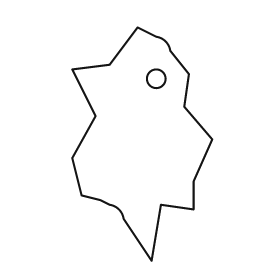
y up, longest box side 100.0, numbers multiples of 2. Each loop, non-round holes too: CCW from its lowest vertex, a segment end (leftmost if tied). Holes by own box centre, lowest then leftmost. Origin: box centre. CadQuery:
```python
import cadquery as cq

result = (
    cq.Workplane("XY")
    .moveTo(4.0, -50.0)
    .lineTo(8.0, -26.0)
    .lineTo(22.0, -28.0)
    .lineTo(22.0, -16.0)
    .lineTo(30.0, 2.0)
    .lineTo(18.0, 16.0)
    .lineTo(20.0, 30.0)
    .lineTo(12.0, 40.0)
    .threePointArc((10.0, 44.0), (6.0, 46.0))
    .lineTo(-2.0, 50.0)
    .lineTo(-14.0, 34.0)
    .lineTo(-30.0, 32.0)
    .lineTo(-20.0, 12.0)
    .lineTo(-30.0, -6.0)
    .lineTo(-26.0, -22.0)
    .lineTo(-18.0, -24.0)
    .lineTo(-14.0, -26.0)
    .threePointArc((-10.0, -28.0), (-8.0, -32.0))
    .close()
    .moveTo(6.0, 28.0)
    .circle(4.0)
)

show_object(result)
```